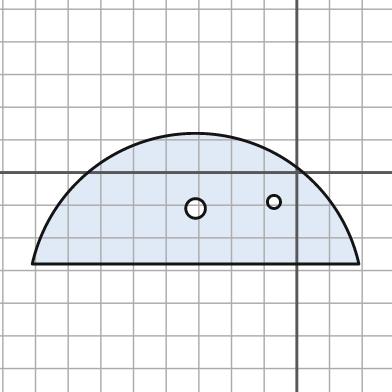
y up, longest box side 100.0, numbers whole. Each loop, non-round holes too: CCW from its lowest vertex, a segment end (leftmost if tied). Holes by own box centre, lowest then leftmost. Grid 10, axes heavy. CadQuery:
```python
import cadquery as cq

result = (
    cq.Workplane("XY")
    .moveTo(-81.0, -28.0)
    .lineTo(19.0, -28.0)
    .threePointArc((-31.0, 12.0), (-81.0, -28.0))
    .close()
    .moveTo(-31.0, -11.0)
    .circle(3.0)
    .moveTo(-7.0, -9.0)
    .circle(2.0)
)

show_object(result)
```